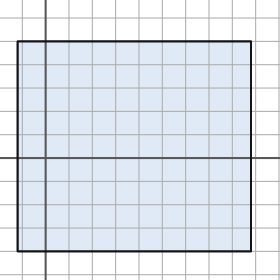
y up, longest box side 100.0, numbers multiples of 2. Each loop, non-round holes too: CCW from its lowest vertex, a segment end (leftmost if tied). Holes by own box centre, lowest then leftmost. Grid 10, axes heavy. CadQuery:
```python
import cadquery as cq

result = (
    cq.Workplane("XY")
    .moveTo(-12.0, -40.0)
    .lineTo(88.0, -40.0)
    .lineTo(88.0, 50.0)
    .lineTo(-12.0, 50.0)
    .close()
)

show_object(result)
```